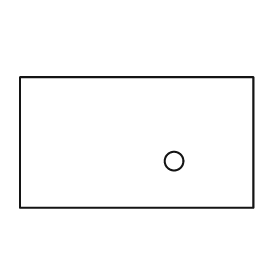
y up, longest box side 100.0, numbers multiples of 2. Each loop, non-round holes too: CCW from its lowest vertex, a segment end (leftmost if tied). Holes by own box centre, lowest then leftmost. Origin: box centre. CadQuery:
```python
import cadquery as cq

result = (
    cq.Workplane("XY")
    .moveTo(-50.0, -28.0)
    .lineTo(50.0, -28.0)
    .lineTo(50.0, 28.0)
    .lineTo(-50.0, 28.0)
    .close()
    .moveTo(16.0, -8.0)
    .circle(4.0)
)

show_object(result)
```